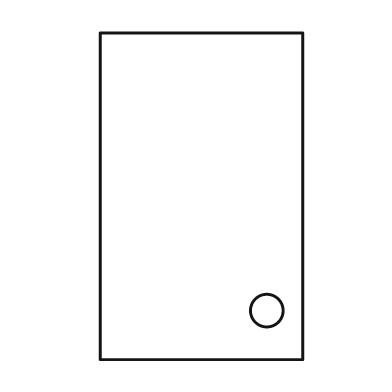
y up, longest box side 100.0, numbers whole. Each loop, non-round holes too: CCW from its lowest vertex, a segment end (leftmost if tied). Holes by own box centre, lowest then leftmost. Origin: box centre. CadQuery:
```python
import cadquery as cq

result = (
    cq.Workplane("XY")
    .moveTo(-31.0, -50.0)
    .lineTo(31.0, -50.0)
    .lineTo(31.0, 50.0)
    .lineTo(-31.0, 50.0)
    .close()
    .moveTo(20.0, -35.0)
    .circle(5.0)
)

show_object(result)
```